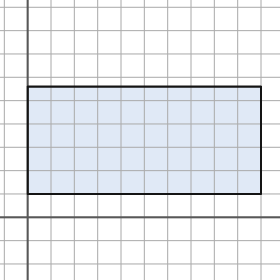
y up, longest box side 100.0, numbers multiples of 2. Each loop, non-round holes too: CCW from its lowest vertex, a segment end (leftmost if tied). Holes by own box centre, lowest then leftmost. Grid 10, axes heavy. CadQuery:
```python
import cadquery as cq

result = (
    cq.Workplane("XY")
    .moveTo(0.0, 10.0)
    .lineTo(100.0, 10.0)
    .lineTo(100.0, 56.0)
    .lineTo(0.0, 56.0)
    .close()
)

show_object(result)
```